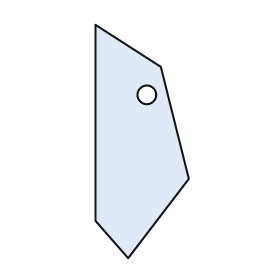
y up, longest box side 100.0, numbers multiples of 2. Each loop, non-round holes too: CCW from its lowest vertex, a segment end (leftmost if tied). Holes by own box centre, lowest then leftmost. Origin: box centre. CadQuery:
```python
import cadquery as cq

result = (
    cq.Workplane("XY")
    .moveTo(-6.0, -50.0)
    .lineTo(20.0, -16.0)
    .lineTo(8.0, 32.0)
    .lineTo(-20.0, 50.0)
    .lineTo(-20.0, -34.0)
    .close()
    .moveTo(2.0, 20.0)
    .circle(4.0)
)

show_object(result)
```